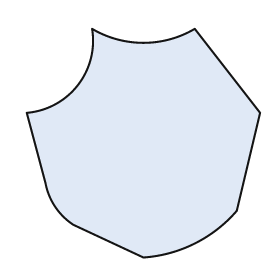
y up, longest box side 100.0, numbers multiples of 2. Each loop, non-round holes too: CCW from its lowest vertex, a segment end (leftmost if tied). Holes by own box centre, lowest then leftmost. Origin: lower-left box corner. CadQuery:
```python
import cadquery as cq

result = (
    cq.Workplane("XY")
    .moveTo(50.0, 0.0)
    .threePointArc((72.0, 6.0), (90.0, 20.0))
    .lineTo(100.0, 62.0)
    .lineTo(72.0, 98.0)
    .threePointArc((50.0, 92.0), (28.0, 98.0))
    .threePointArc((22.0, 74.0), (0.0, 62.0))
    .lineTo(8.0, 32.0)
    .threePointArc((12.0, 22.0), (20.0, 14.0))
    .close()
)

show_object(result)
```